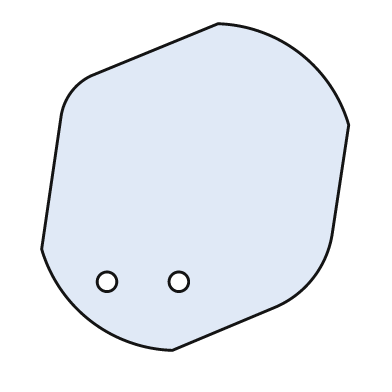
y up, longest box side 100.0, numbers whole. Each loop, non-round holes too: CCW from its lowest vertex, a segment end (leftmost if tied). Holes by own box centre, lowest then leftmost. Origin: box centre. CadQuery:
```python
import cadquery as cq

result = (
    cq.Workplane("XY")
    .moveTo(-7.0, -50.0)
    .lineTo(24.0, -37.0)
    .threePointArc((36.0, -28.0), (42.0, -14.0))
    .lineTo(47.0, 19.0)
    .threePointArc((32.0, 41.0), (7.0, 50.0))
    .lineTo(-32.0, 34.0)
    .threePointArc((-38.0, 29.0), (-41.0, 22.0))
    .lineTo(-47.0, -19.0)
    .threePointArc((-32.0, -41.0), (-7.0, -50.0))
    .close()
    .moveTo(-27.0, -29.0)
    .circle(3.0)
    .moveTo(-5.0, -29.0)
    .circle(3.0)
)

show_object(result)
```